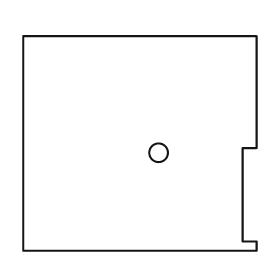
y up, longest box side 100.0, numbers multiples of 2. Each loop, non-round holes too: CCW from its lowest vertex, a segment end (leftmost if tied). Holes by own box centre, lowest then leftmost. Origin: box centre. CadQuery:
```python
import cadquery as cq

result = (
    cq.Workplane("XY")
    .moveTo(-50.0, -46.0)
    .lineTo(50.0, -46.0)
    .lineTo(50.0, -42.0)
    .lineTo(44.0, -42.0)
    .lineTo(44.0, -2.0)
    .lineTo(50.0, -2.0)
    .lineTo(50.0, 46.0)
    .lineTo(-50.0, 46.0)
    .close()
    .moveTo(8.0, -4.0)
    .circle(4.0)
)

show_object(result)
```